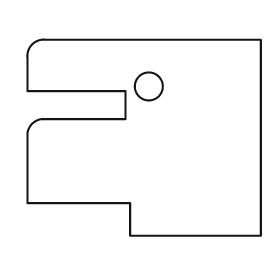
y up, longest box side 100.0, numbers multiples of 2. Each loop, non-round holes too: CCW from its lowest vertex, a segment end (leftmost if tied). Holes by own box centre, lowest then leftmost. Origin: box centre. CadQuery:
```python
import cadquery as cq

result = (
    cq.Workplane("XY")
    .moveTo(-6.0, -42.0)
    .lineTo(50.0, -42.0)
    .lineTo(50.0, 42.0)
    .lineTo(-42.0, 42.0)
    .threePointArc((-48.0, 40.0), (-50.0, 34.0))
    .lineTo(-50.0, 20.0)
    .lineTo(-8.0, 20.0)
    .lineTo(-8.0, 8.0)
    .lineTo(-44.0, 8.0)
    .threePointArc((-48.0, 6.0), (-50.0, 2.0))
    .lineTo(-50.0, -28.0)
    .lineTo(-6.0, -28.0)
    .close()
    .moveTo(2.0, 22.0)
    .circle(6.0)
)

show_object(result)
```